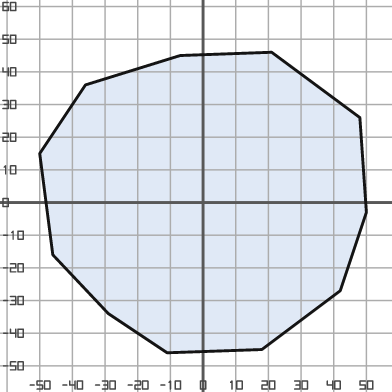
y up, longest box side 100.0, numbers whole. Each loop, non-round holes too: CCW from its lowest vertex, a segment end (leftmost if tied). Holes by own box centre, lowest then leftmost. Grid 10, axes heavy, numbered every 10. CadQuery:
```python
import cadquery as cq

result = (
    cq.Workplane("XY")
    .moveTo(-11.0, -46.0)
    .lineTo(18.0, -45.0)
    .lineTo(42.0, -27.0)
    .lineTo(50.0, -3.0)
    .lineTo(48.0, 26.0)
    .lineTo(21.0, 46.0)
    .lineTo(-7.0, 45.0)
    .lineTo(-36.0, 36.0)
    .lineTo(-50.0, 15.0)
    .lineTo(-46.0, -16.0)
    .lineTo(-29.0, -34.0)
    .close()
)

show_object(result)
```